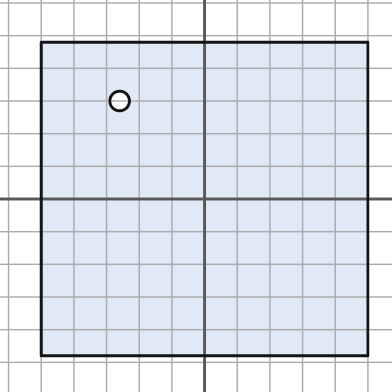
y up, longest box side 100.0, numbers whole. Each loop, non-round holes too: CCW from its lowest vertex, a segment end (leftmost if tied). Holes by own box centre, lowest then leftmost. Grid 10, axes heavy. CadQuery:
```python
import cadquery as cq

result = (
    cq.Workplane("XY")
    .moveTo(-50.0, -48.0)
    .lineTo(50.0, -48.0)
    .lineTo(50.0, 48.0)
    .lineTo(-50.0, 48.0)
    .close()
    .moveTo(-26.0, 30.0)
    .circle(3.0)
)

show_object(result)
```